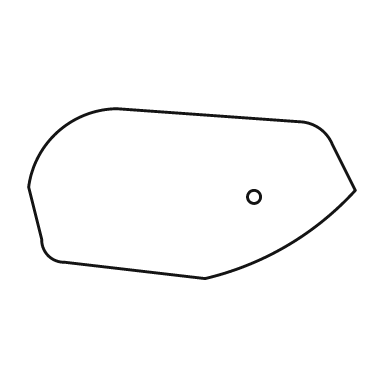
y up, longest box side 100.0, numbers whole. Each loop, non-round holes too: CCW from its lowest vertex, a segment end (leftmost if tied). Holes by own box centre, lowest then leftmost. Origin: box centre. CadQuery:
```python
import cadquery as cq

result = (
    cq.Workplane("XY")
    .moveTo(4.0, -26.0)
    .threePointArc((29.0, -16.0), (50.0, 1.0))
    .lineTo(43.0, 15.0)
    .threePointArc((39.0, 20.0), (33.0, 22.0))
    .lineTo(-23.0, 26.0)
    .threePointArc((-41.0, 19.0), (-50.0, 2.0))
    .lineTo(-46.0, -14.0)
    .threePointArc((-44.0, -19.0), (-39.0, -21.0))
    .close()
    .moveTo(19.0, -1.0)
    .circle(2.0)
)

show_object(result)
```